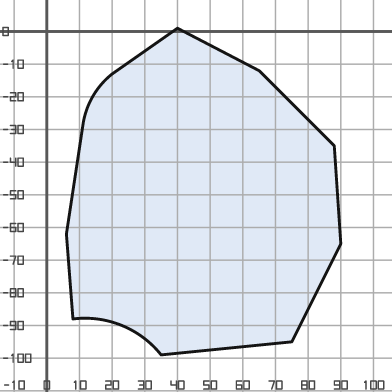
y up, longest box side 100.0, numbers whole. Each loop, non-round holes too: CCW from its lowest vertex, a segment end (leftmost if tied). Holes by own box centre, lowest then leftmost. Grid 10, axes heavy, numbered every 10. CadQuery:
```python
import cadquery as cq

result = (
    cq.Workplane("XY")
    .moveTo(35.0, -99.0)
    .lineTo(75.0, -95.0)
    .lineTo(90.0, -65.0)
    .lineTo(88.0, -35.0)
    .lineTo(65.0, -12.0)
    .lineTo(40.0, 1.0)
    .lineTo(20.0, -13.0)
    .threePointArc((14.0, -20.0), (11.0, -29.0))
    .lineTo(6.0, -62.0)
    .lineTo(8.0, -88.0)
    .threePointArc((23.0, -90.0), (35.0, -99.0))
    .close()
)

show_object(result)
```